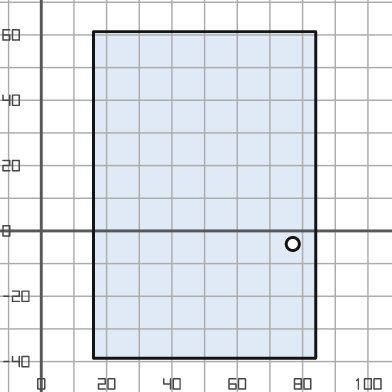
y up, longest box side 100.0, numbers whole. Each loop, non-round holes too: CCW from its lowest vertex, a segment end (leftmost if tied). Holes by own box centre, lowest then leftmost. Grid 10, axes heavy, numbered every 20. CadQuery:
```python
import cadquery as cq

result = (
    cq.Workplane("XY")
    .moveTo(16.0, -39.0)
    .lineTo(84.0, -39.0)
    .lineTo(84.0, 61.0)
    .lineTo(16.0, 61.0)
    .close()
    .moveTo(77.0, -4.0)
    .circle(2.0)
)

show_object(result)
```